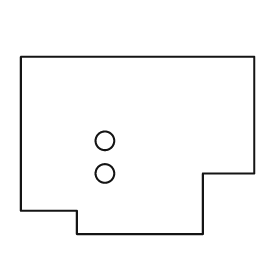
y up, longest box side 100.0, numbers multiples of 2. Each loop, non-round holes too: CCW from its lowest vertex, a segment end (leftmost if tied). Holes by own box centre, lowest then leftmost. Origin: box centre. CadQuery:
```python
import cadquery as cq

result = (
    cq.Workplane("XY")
    .moveTo(-26.0, -38.0)
    .lineTo(28.0, -38.0)
    .lineTo(28.0, -12.0)
    .lineTo(50.0, -12.0)
    .lineTo(50.0, 38.0)
    .lineTo(-50.0, 38.0)
    .lineTo(-50.0, -28.0)
    .lineTo(-26.0, -28.0)
    .close()
    .moveTo(-14.0, -12.0)
    .circle(4.0)
    .moveTo(-14.0, 2.0)
    .circle(4.0)
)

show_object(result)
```